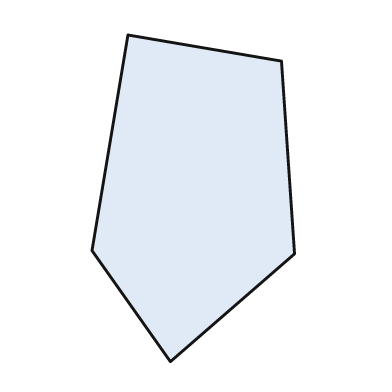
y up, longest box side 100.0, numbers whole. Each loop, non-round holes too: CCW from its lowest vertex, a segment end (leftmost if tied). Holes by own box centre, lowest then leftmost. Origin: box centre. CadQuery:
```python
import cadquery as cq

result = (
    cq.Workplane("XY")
    .moveTo(-7.0, -50.0)
    .lineTo(31.0, -17.0)
    .lineTo(27.0, 42.0)
    .lineTo(-20.0, 50.0)
    .lineTo(-31.0, -16.0)
    .close()
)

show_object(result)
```